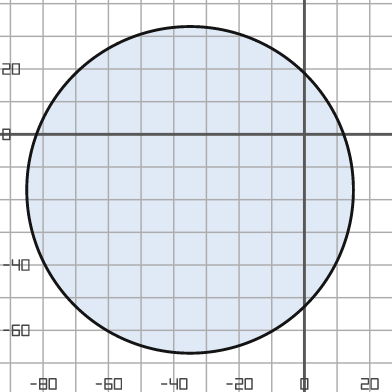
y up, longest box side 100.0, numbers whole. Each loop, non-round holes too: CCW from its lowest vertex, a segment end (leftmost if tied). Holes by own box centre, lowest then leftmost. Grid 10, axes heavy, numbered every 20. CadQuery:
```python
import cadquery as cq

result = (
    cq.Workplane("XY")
    .moveTo(-35.0, -17.0)
    .circle(50.0)
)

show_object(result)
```